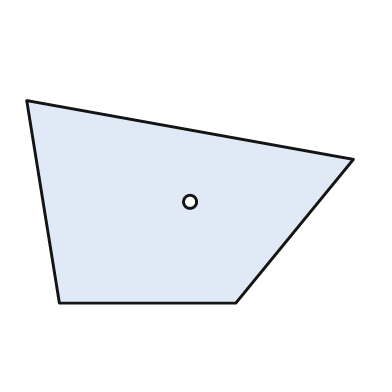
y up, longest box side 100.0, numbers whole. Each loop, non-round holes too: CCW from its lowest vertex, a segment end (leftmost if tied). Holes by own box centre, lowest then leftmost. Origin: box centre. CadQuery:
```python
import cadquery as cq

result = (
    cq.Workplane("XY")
    .moveTo(-40.0, -31.0)
    .lineTo(14.0, -31.0)
    .lineTo(50.0, 13.0)
    .lineTo(-50.0, 31.0)
    .close()
    .moveTo(0.0, 0.0)
    .circle(2.0)
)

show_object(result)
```